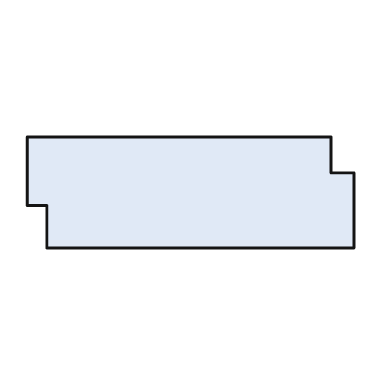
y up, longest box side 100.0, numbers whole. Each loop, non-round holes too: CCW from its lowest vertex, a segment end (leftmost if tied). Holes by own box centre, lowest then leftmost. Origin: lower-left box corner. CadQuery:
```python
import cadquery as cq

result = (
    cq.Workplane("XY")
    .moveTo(6.0, 0.0)
    .lineTo(100.0, 0.0)
    .lineTo(100.0, 23.0)
    .lineTo(93.0, 23.0)
    .lineTo(93.0, 34.0)
    .lineTo(0.0, 34.0)
    .lineTo(0.0, 13.0)
    .lineTo(6.0, 13.0)
    .close()
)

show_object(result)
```